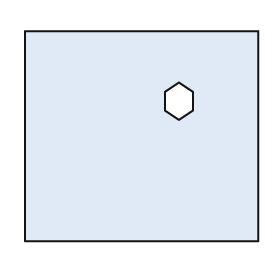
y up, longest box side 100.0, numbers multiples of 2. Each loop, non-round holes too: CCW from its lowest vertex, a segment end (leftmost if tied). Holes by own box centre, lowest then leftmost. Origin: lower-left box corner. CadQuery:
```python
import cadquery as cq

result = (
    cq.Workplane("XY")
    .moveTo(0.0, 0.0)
    .lineTo(100.0, 0.0)
    .lineTo(100.0, 90.0)
    .lineTo(0.0, 90.0)
    .close()
    .moveTo(66.0, 52.0)
    .lineTo(72.0, 56.0)
    .lineTo(72.0, 64.0)
    .lineTo(66.0, 68.0)
    .lineTo(60.0, 64.0)
    .lineTo(60.0, 56.0)
    .close()
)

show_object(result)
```